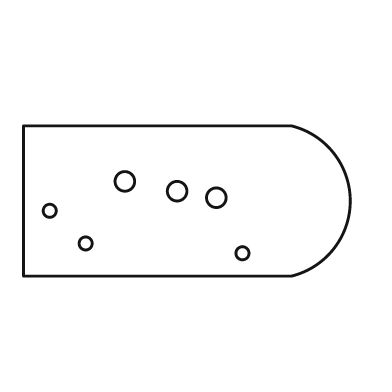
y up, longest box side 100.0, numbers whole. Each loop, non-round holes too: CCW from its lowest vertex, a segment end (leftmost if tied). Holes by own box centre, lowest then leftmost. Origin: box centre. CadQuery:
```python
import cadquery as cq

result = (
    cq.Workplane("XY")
    .moveTo(-50.0, -23.0)
    .lineTo(32.0, -23.0)
    .threePointArc((50.0, 0.0), (32.0, 23.0))
    .lineTo(-50.0, 23.0)
    .close()
    .moveTo(17.0, -16.0)
    .circle(2.0)
    .moveTo(-31.0, -13.0)
    .circle(2.0)
    .moveTo(-42.0, -3.0)
    .circle(2.0)
    .moveTo(9.0, 1.0)
    .circle(3.0)
    .moveTo(-3.0, 3.0)
    .circle(3.0)
    .moveTo(-19.0, 6.0)
    .circle(3.0)
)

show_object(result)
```